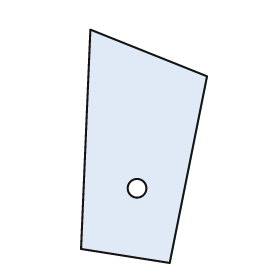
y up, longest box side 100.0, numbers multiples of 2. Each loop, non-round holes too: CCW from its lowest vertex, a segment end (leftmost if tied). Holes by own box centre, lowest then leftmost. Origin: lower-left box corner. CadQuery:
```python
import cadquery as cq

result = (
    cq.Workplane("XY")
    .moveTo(38.0, 0.0)
    .lineTo(54.0, 80.0)
    .lineTo(4.0, 100.0)
    .lineTo(0.0, 6.0)
    .close()
    .moveTo(24.0, 32.0)
    .circle(4.0)
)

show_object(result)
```